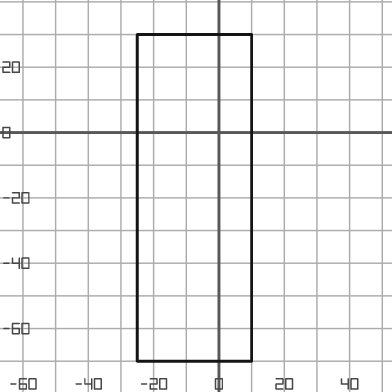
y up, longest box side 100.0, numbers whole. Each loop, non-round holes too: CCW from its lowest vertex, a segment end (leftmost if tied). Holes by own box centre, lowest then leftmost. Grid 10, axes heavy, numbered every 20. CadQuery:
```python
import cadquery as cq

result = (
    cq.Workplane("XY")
    .moveTo(-25.0, -70.0)
    .lineTo(10.0, -70.0)
    .lineTo(10.0, 30.0)
    .lineTo(-25.0, 30.0)
    .close()
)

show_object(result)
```